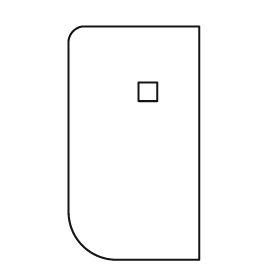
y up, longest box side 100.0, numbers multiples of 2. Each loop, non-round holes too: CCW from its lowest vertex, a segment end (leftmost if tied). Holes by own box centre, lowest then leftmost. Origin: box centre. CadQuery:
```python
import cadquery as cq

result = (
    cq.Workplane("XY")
    .moveTo(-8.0, -50.0)
    .lineTo(28.0, -50.0)
    .lineTo(28.0, 50.0)
    .lineTo(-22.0, 50.0)
    .threePointArc((-26.0, 48.0), (-28.0, 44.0))
    .lineTo(-28.0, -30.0)
    .threePointArc((-22.0, -44.0), (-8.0, -50.0))
    .close()
    .moveTo(2.0, 18.0)
    .lineTo(10.0, 18.0)
    .lineTo(10.0, 26.0)
    .lineTo(2.0, 26.0)
    .close()
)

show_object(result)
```